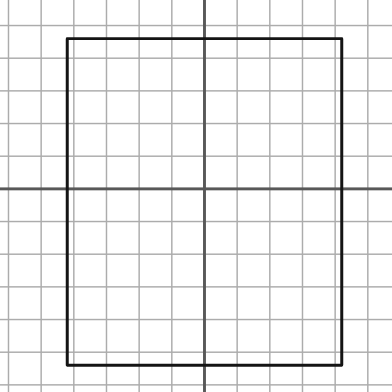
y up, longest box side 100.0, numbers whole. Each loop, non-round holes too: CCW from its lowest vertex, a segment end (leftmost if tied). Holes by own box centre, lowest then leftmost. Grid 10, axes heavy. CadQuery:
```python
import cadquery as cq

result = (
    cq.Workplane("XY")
    .moveTo(-42.0, -54.0)
    .lineTo(42.0, -54.0)
    .lineTo(42.0, 46.0)
    .lineTo(-42.0, 46.0)
    .close()
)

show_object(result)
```